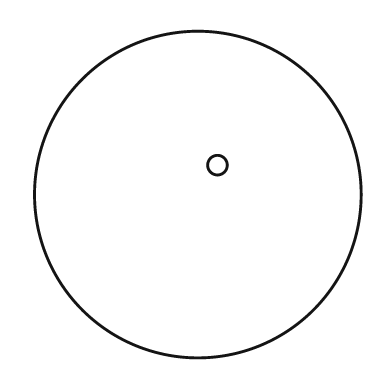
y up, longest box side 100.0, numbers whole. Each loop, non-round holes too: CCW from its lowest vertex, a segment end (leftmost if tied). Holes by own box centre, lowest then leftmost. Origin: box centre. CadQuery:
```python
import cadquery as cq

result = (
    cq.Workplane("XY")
    .moveTo(0.0, 0.0)
    .circle(50.0)
    .moveTo(6.0, 9.0)
    .circle(3.0)
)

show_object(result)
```